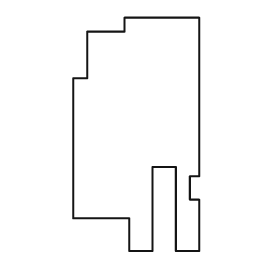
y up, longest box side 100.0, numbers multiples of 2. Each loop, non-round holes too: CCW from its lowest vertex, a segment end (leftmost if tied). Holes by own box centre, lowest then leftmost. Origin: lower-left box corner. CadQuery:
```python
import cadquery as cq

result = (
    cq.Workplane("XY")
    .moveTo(24.0, 0.0)
    .lineTo(34.0, 0.0)
    .lineTo(34.0, 36.0)
    .lineTo(44.0, 36.0)
    .lineTo(44.0, 0.0)
    .lineTo(54.0, 0.0)
    .lineTo(54.0, 22.0)
    .lineTo(50.0, 22.0)
    .lineTo(50.0, 32.0)
    .lineTo(54.0, 32.0)
    .lineTo(54.0, 100.0)
    .lineTo(22.0, 100.0)
    .lineTo(22.0, 94.0)
    .lineTo(6.0, 94.0)
    .lineTo(6.0, 74.0)
    .lineTo(0.0, 74.0)
    .lineTo(0.0, 14.0)
    .lineTo(24.0, 14.0)
    .close()
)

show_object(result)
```